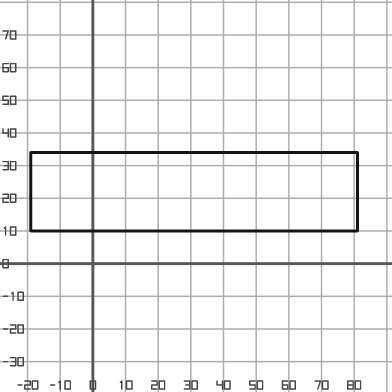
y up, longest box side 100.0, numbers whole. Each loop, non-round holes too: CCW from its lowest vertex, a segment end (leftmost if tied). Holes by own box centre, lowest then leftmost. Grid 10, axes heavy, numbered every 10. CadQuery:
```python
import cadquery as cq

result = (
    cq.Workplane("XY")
    .moveTo(-19.0, 10.0)
    .lineTo(81.0, 10.0)
    .lineTo(81.0, 34.0)
    .lineTo(-19.0, 34.0)
    .close()
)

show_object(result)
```